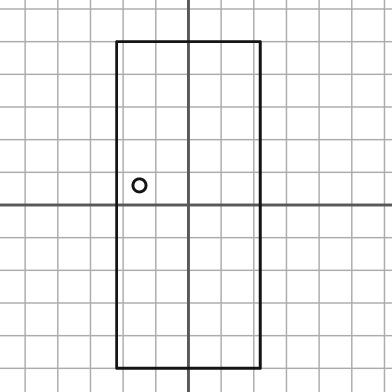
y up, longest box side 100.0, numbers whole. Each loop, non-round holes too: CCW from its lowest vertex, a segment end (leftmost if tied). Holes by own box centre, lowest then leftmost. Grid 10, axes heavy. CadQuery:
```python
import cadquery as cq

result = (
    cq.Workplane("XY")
    .moveTo(-22.0, -50.0)
    .lineTo(22.0, -50.0)
    .lineTo(22.0, 50.0)
    .lineTo(-22.0, 50.0)
    .close()
    .moveTo(-15.0, 6.0)
    .circle(2.0)
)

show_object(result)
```